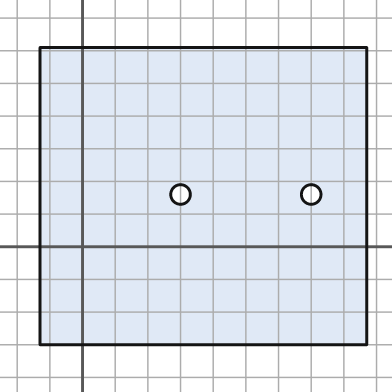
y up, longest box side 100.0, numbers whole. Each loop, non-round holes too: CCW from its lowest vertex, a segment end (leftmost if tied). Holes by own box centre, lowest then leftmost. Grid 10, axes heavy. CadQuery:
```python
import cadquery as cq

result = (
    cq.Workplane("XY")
    .moveTo(-13.0, -30.0)
    .lineTo(87.0, -30.0)
    .lineTo(87.0, 61.0)
    .lineTo(-13.0, 61.0)
    .close()
    .moveTo(30.0, 16.0)
    .circle(3.0)
    .moveTo(70.0, 16.0)
    .circle(3.0)
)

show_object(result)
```